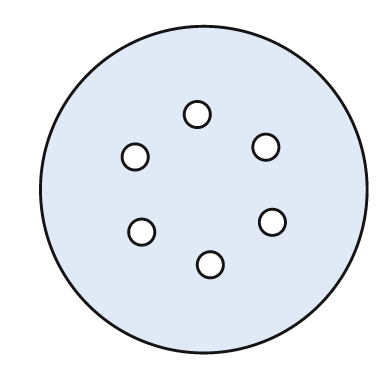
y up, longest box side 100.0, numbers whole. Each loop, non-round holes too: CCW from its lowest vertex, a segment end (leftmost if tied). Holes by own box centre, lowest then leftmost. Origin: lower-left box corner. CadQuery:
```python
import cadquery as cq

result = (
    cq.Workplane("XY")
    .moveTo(50.0, 50.0)
    .circle(50.0)
    .moveTo(52.0, 27.0)
    .circle(4.0)
    .moveTo(31.0, 37.0)
    .circle(4.0)
    .moveTo(71.0, 40.0)
    .circle(4.0)
    .moveTo(29.0, 60.0)
    .circle(4.0)
    .moveTo(69.0, 63.0)
    .circle(4.0)
    .moveTo(48.0, 73.0)
    .circle(4.0)
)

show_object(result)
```